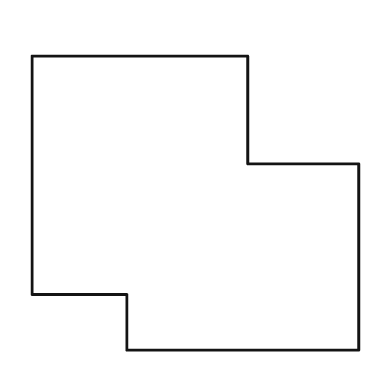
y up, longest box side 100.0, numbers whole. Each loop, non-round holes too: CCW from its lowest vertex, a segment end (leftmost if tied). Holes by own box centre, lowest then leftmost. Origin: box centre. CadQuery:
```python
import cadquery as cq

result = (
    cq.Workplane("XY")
    .moveTo(-21.0, -45.0)
    .lineTo(50.0, -45.0)
    .lineTo(50.0, 12.0)
    .lineTo(16.0, 12.0)
    .lineTo(16.0, 45.0)
    .lineTo(-50.0, 45.0)
    .lineTo(-50.0, -28.0)
    .lineTo(-21.0, -28.0)
    .close()
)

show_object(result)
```